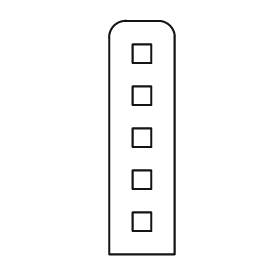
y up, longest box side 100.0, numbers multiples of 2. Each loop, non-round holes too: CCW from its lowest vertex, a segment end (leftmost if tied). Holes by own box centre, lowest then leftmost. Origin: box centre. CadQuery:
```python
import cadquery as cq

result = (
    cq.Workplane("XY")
    .moveTo(-14.0, -50.0)
    .lineTo(14.0, -50.0)
    .lineTo(14.0, 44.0)
    .threePointArc((12.0, 48.0), (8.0, 50.0))
    .lineTo(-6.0, 50.0)
    .threePointArc((-12.0, 48.0), (-14.0, 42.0))
    .close()
    .moveTo(-4.0, -40.0)
    .lineTo(4.0, -40.0)
    .lineTo(4.0, -32.0)
    .lineTo(-4.0, -32.0)
    .close()
    .moveTo(-4.0, -22.0)
    .lineTo(4.0, -22.0)
    .lineTo(4.0, -14.0)
    .lineTo(-4.0, -14.0)
    .close()
    .moveTo(-4.0, -4.0)
    .lineTo(4.0, -4.0)
    .lineTo(4.0, 4.0)
    .lineTo(-4.0, 4.0)
    .close()
    .moveTo(-4.0, 14.0)
    .lineTo(4.0, 14.0)
    .lineTo(4.0, 22.0)
    .lineTo(-4.0, 22.0)
    .close()
    .moveTo(-4.0, 32.0)
    .lineTo(4.0, 32.0)
    .lineTo(4.0, 40.0)
    .lineTo(-4.0, 40.0)
    .close()
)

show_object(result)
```